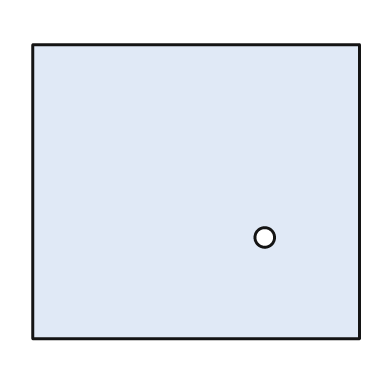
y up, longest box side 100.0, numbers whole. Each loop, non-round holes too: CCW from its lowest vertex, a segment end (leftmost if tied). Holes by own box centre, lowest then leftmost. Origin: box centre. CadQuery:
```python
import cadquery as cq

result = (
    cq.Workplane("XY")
    .moveTo(-50.0, -45.0)
    .lineTo(50.0, -45.0)
    .lineTo(50.0, 45.0)
    .lineTo(-50.0, 45.0)
    .close()
    .moveTo(21.0, -14.0)
    .circle(3.0)
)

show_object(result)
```